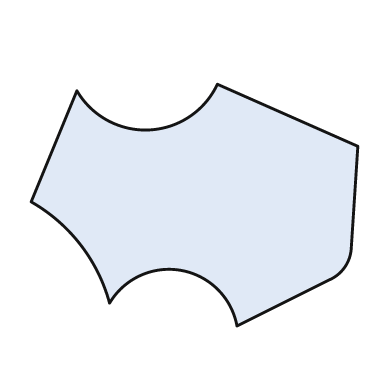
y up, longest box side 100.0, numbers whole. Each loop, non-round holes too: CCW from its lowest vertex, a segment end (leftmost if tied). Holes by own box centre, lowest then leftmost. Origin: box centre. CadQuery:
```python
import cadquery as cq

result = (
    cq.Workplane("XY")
    .moveTo(13.0, -37.0)
    .lineTo(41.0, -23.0)
    .threePointArc((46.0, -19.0), (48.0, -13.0))
    .lineTo(50.0, 18.0)
    .lineTo(7.0, 37.0)
    .threePointArc((-14.0, 23.0), (-36.0, 35.0))
    .lineTo(-50.0, 1.0)
    .threePointArc((-35.0, -12.0), (-26.0, -30.0))
    .threePointArc((-4.0, -20.0), (13.0, -37.0))
    .close()
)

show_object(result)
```